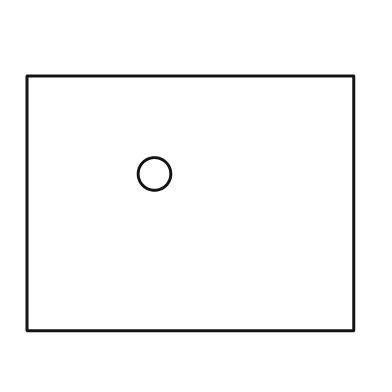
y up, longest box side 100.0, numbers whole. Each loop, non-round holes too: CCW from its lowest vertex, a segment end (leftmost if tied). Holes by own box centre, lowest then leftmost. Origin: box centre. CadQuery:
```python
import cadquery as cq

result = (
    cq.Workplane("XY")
    .moveTo(-50.0, -39.0)
    .lineTo(50.0, -39.0)
    .lineTo(50.0, 39.0)
    .lineTo(-50.0, 39.0)
    .close()
    .moveTo(-11.0, 9.0)
    .circle(5.0)
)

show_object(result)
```